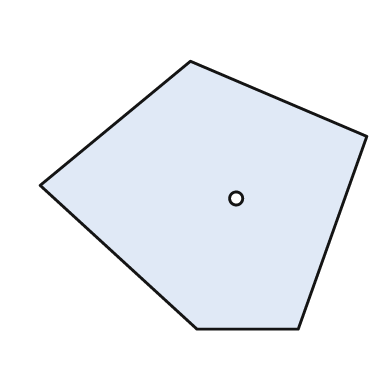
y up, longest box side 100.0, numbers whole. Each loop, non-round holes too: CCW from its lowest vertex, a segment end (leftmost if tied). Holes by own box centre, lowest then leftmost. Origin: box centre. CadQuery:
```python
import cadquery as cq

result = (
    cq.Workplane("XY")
    .moveTo(-2.0, -41.0)
    .lineTo(29.0, -41.0)
    .lineTo(50.0, 18.0)
    .lineTo(-4.0, 41.0)
    .lineTo(-50.0, 3.0)
    .close()
    .moveTo(10.0, -1.0)
    .circle(2.0)
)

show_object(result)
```